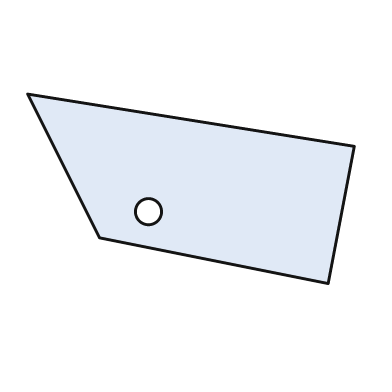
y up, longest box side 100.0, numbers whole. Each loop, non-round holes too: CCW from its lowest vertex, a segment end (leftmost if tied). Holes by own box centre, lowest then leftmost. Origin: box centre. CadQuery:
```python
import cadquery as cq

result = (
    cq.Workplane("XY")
    .moveTo(42.0, -29.0)
    .lineTo(50.0, 13.0)
    .lineTo(-50.0, 29.0)
    .lineTo(-28.0, -15.0)
    .close()
    .moveTo(-13.0, -7.0)
    .circle(4.0)
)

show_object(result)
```